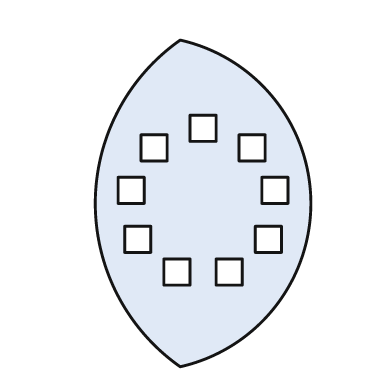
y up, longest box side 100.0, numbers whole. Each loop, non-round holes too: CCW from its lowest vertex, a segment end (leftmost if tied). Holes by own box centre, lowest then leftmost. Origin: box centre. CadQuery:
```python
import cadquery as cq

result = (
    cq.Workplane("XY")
    .moveTo(-7.0, -50.0)
    .threePointArc((33.0, 0.0), (-7.0, 50.0))
    .threePointArc((-33.0, 0.0), (-7.0, -50.0))
    .close()
    .moveTo(-12.0, -25.0)
    .lineTo(-4.0, -25.0)
    .lineTo(-4.0, -17.0)
    .lineTo(-12.0, -17.0)
    .close()
    .moveTo(4.0, -25.0)
    .lineTo(12.0, -25.0)
    .lineTo(12.0, -17.0)
    .lineTo(4.0, -17.0)
    .close()
    .moveTo(-24.0, -15.0)
    .lineTo(-16.0, -15.0)
    .lineTo(-16.0, -7.0)
    .lineTo(-24.0, -7.0)
    .close()
    .moveTo(16.0, -15.0)
    .lineTo(24.0, -15.0)
    .lineTo(24.0, -7.0)
    .lineTo(16.0, -7.0)
    .close()
    .moveTo(-26.0, 0.0)
    .lineTo(-18.0, 0.0)
    .lineTo(-18.0, 8.0)
    .lineTo(-26.0, 8.0)
    .close()
    .moveTo(18.0, 0.0)
    .lineTo(26.0, 0.0)
    .lineTo(26.0, 8.0)
    .lineTo(18.0, 8.0)
    .close()
    .moveTo(-19.0, 13.0)
    .lineTo(-11.0, 13.0)
    .lineTo(-11.0, 21.0)
    .lineTo(-19.0, 21.0)
    .close()
    .moveTo(11.0, 13.0)
    .lineTo(19.0, 13.0)
    .lineTo(19.0, 21.0)
    .lineTo(11.0, 21.0)
    .close()
    .moveTo(-4.0, 19.0)
    .lineTo(4.0, 19.0)
    .lineTo(4.0, 27.0)
    .lineTo(-4.0, 27.0)
    .close()
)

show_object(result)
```